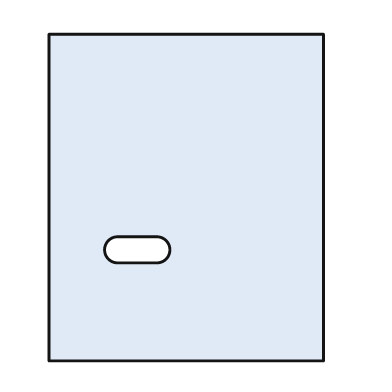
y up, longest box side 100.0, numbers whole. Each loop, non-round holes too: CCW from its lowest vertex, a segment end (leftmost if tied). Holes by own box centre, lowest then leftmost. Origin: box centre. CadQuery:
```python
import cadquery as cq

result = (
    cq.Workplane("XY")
    .moveTo(-42.0, -50.0)
    .lineTo(42.0, -50.0)
    .lineTo(42.0, 50.0)
    .lineTo(-42.0, 50.0)
    .close()
    .moveTo(-21.0, -20.0)
    .lineTo(-9.0, -20.0)
    .threePointArc((-5.0, -16.0), (-9.0, -12.0))
    .lineTo(-21.0, -12.0)
    .threePointArc((-25.0, -16.0), (-21.0, -20.0))
    .close()
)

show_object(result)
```